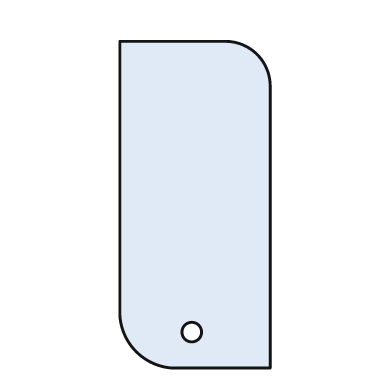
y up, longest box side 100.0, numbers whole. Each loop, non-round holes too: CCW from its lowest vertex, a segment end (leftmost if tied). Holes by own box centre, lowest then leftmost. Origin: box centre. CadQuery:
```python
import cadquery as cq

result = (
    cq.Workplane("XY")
    .moveTo(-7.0, -50.0)
    .lineTo(23.0, -50.0)
    .lineTo(23.0, 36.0)
    .threePointArc((19.0, 46.0), (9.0, 50.0))
    .lineTo(-23.0, 50.0)
    .lineTo(-23.0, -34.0)
    .threePointArc((-18.0, -45.0), (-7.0, -50.0))
    .close()
    .moveTo(-1.0, -39.0)
    .circle(3.0)
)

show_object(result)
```